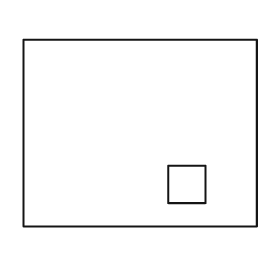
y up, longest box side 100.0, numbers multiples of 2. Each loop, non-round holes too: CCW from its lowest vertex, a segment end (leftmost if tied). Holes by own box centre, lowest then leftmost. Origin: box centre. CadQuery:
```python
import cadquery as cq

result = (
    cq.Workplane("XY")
    .moveTo(-50.0, -40.0)
    .lineTo(50.0, -40.0)
    .lineTo(50.0, 40.0)
    .lineTo(-50.0, 40.0)
    .close()
    .moveTo(12.0, -30.0)
    .lineTo(28.0, -30.0)
    .lineTo(28.0, -14.0)
    .lineTo(12.0, -14.0)
    .close()
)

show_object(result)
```